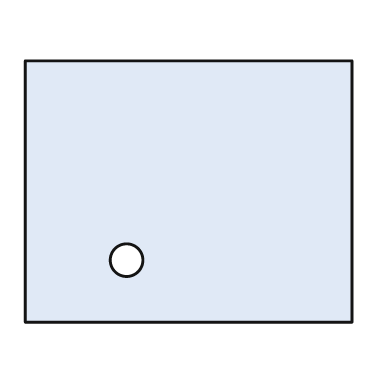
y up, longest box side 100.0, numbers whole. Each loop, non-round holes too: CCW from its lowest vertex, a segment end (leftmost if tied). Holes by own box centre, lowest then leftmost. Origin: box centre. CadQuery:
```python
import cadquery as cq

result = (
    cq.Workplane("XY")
    .moveTo(-50.0, -40.0)
    .lineTo(50.0, -40.0)
    .lineTo(50.0, 40.0)
    .lineTo(-50.0, 40.0)
    .close()
    .moveTo(-19.0, -21.0)
    .circle(5.0)
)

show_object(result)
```